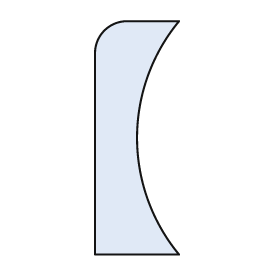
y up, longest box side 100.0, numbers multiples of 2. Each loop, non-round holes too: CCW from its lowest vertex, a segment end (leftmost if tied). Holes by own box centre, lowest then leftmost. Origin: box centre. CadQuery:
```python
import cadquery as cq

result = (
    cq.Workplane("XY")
    .moveTo(-18.0, -50.0)
    .lineTo(18.0, -50.0)
    .threePointArc((0.0, 0.0), (18.0, 50.0))
    .lineTo(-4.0, 50.0)
    .threePointArc((-14.0, 46.0), (-18.0, 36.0))
    .close()
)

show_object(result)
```